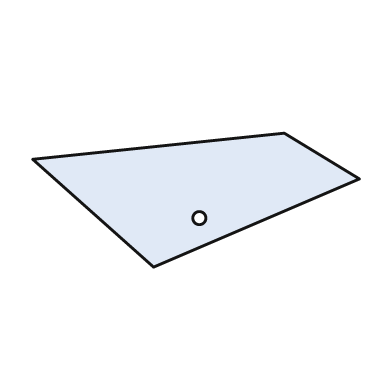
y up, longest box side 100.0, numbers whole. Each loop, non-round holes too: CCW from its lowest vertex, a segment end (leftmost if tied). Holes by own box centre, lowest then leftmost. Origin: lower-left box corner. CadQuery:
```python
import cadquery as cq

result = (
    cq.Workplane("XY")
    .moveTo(37.0, 0.0)
    .lineTo(100.0, 27.0)
    .lineTo(77.0, 41.0)
    .lineTo(0.0, 33.0)
    .close()
    .moveTo(51.0, 15.0)
    .circle(2.0)
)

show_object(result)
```